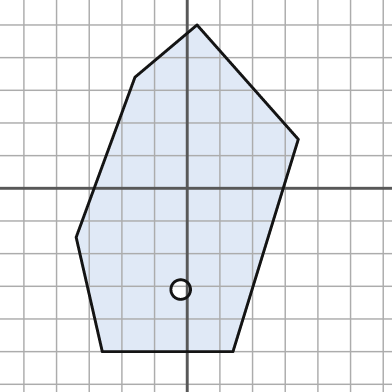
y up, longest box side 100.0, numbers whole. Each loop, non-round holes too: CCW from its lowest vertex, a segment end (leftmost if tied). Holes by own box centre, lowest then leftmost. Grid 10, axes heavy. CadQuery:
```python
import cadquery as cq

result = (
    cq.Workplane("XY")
    .moveTo(-26.0, -50.0)
    .lineTo(14.0, -50.0)
    .lineTo(34.0, 15.0)
    .lineTo(3.0, 50.0)
    .lineTo(-16.0, 34.0)
    .lineTo(-34.0, -15.0)
    .close()
    .moveTo(-2.0, -31.0)
    .circle(3.0)
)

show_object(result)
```